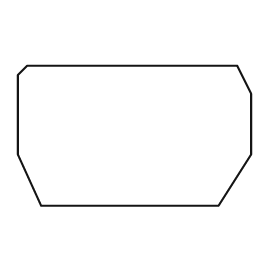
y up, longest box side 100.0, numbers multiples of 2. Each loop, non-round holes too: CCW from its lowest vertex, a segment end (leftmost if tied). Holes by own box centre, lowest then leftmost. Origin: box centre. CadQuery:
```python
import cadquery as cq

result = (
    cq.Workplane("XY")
    .moveTo(-40.0, -30.0)
    .lineTo(36.0, -30.0)
    .lineTo(50.0, -8.0)
    .lineTo(50.0, 18.0)
    .lineTo(44.0, 30.0)
    .lineTo(-46.0, 30.0)
    .lineTo(-50.0, 26.0)
    .lineTo(-50.0, -8.0)
    .close()
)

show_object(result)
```